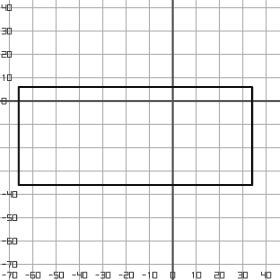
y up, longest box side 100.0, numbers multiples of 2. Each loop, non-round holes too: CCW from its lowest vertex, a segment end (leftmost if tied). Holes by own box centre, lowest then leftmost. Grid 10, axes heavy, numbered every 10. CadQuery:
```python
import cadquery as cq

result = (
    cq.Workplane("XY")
    .moveTo(-66.0, -36.0)
    .lineTo(34.0, -36.0)
    .lineTo(34.0, 6.0)
    .lineTo(-66.0, 6.0)
    .close()
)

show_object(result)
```